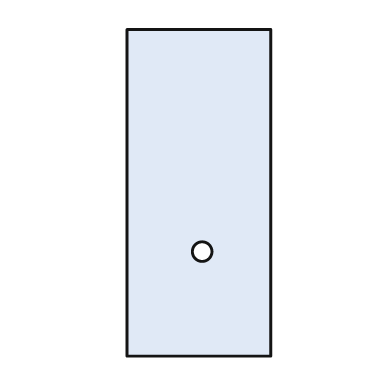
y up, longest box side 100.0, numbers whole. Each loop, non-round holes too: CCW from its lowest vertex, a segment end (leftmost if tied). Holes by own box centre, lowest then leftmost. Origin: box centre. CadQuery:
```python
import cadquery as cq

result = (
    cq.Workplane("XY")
    .moveTo(-22.0, -50.0)
    .lineTo(22.0, -50.0)
    .lineTo(22.0, 50.0)
    .lineTo(-22.0, 50.0)
    .close()
    .moveTo(1.0, -18.0)
    .circle(3.0)
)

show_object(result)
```